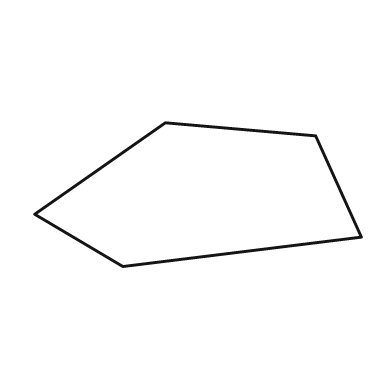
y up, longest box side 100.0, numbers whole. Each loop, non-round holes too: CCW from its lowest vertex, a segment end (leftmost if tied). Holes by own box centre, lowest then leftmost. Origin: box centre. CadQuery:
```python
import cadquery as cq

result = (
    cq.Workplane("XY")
    .moveTo(-23.0, -22.0)
    .lineTo(50.0, -13.0)
    .lineTo(36.0, 18.0)
    .lineTo(-10.0, 22.0)
    .lineTo(-50.0, -6.0)
    .close()
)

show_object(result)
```